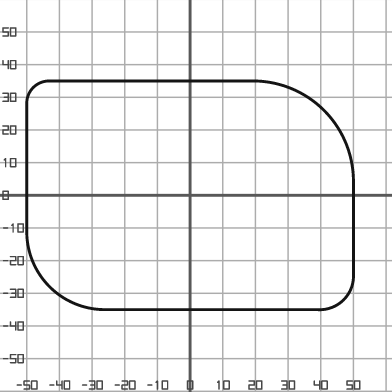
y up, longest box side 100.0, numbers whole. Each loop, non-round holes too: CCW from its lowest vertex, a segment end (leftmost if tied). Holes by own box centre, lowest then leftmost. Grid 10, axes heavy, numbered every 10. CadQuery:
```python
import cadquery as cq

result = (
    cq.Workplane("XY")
    .moveTo(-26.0, -35.0)
    .lineTo(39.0, -35.0)
    .threePointArc((47.0, -32.0), (50.0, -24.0))
    .lineTo(50.0, 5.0)
    .threePointArc((41.0, 26.0), (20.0, 35.0))
    .lineTo(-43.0, 35.0)
    .threePointArc((-48.0, 33.0), (-50.0, 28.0))
    .lineTo(-50.0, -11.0)
    .threePointArc((-43.0, -28.0), (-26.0, -35.0))
    .close()
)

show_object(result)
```